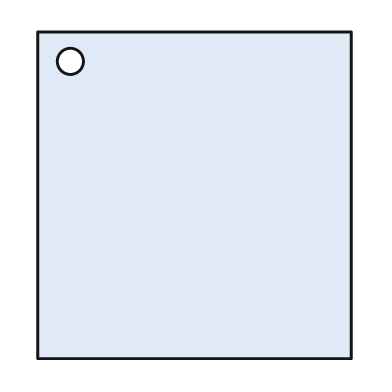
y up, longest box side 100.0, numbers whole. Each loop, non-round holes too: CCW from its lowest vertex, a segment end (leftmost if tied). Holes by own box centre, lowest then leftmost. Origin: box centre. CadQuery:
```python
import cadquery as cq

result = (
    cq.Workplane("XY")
    .moveTo(-48.0, -50.0)
    .lineTo(48.0, -50.0)
    .lineTo(48.0, 50.0)
    .lineTo(-48.0, 50.0)
    .close()
    .moveTo(-38.0, 41.0)
    .circle(4.0)
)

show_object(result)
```